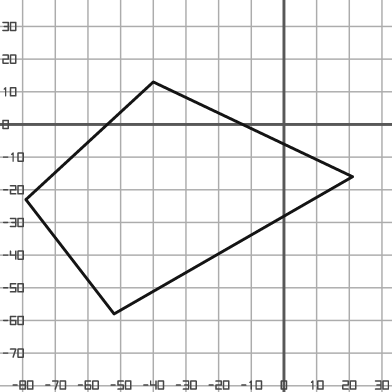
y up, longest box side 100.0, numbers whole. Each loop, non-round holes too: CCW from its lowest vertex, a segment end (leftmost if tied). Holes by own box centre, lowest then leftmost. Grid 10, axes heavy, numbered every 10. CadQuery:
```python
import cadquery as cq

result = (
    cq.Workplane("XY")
    .moveTo(-52.0, -58.0)
    .lineTo(21.0, -16.0)
    .lineTo(-40.0, 13.0)
    .lineTo(-79.0, -23.0)
    .close()
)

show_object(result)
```